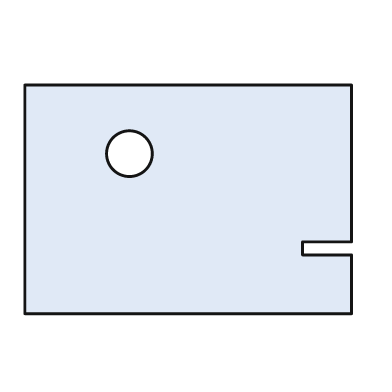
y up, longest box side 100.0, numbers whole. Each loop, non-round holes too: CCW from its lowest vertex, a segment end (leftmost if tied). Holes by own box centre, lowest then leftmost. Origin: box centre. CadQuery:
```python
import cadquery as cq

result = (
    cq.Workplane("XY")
    .moveTo(-50.0, -35.0)
    .lineTo(50.0, -35.0)
    .lineTo(50.0, -17.0)
    .lineTo(35.0, -17.0)
    .lineTo(35.0, -13.0)
    .lineTo(50.0, -13.0)
    .lineTo(50.0, 35.0)
    .lineTo(-50.0, 35.0)
    .close()
    .moveTo(-18.0, 14.0)
    .circle(7.0)
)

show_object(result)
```